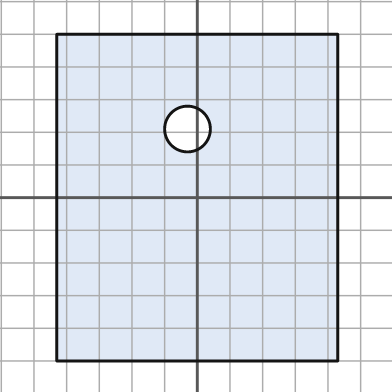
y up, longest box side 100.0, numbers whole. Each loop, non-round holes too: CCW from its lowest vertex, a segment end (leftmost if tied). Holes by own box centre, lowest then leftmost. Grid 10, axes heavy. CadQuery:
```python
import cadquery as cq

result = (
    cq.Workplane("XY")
    .moveTo(-43.0, -50.0)
    .lineTo(43.0, -50.0)
    .lineTo(43.0, 50.0)
    .lineTo(-43.0, 50.0)
    .close()
    .moveTo(-3.0, 21.0)
    .circle(7.0)
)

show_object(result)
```